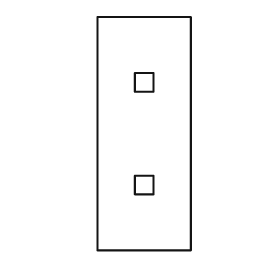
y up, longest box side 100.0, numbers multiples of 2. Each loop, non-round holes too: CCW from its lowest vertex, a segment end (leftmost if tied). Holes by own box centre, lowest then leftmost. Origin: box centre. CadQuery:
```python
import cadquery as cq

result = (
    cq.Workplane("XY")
    .moveTo(-20.0, -50.0)
    .lineTo(20.0, -50.0)
    .lineTo(20.0, 50.0)
    .lineTo(-20.0, 50.0)
    .close()
    .moveTo(-4.0, -26.0)
    .lineTo(4.0, -26.0)
    .lineTo(4.0, -18.0)
    .lineTo(-4.0, -18.0)
    .close()
    .moveTo(-4.0, 18.0)
    .lineTo(4.0, 18.0)
    .lineTo(4.0, 26.0)
    .lineTo(-4.0, 26.0)
    .close()
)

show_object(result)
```